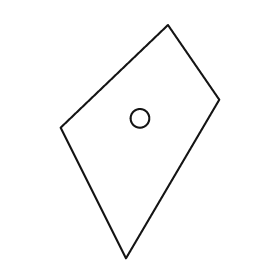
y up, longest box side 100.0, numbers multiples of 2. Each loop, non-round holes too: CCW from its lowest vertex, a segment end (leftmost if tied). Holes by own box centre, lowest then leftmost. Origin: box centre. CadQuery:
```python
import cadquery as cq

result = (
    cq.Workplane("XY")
    .moveTo(-6.0, -50.0)
    .lineTo(34.0, 18.0)
    .lineTo(12.0, 50.0)
    .lineTo(-34.0, 6.0)
    .close()
    .moveTo(0.0, 10.0)
    .circle(4.0)
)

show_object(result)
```